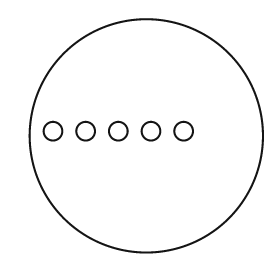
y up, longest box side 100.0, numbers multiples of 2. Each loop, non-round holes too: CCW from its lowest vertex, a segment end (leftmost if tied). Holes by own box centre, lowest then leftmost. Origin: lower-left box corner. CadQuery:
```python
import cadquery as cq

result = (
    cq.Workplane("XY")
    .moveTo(50.0, 50.0)
    .circle(50.0)
    .moveTo(10.0, 52.0)
    .circle(4.0)
    .moveTo(24.0, 52.0)
    .circle(4.0)
    .moveTo(38.0, 52.0)
    .circle(4.0)
    .moveTo(52.0, 52.0)
    .circle(4.0)
    .moveTo(66.0, 52.0)
    .circle(4.0)
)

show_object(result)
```